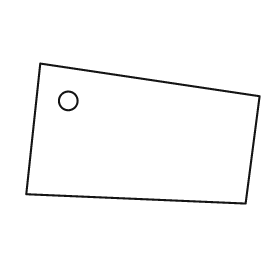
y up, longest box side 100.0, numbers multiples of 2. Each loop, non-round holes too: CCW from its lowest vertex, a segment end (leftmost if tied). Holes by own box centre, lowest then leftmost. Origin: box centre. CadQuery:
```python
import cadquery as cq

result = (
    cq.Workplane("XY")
    .moveTo(44.0, -30.0)
    .lineTo(50.0, 16.0)
    .lineTo(-44.0, 30.0)
    .lineTo(-50.0, -26.0)
    .close()
    .moveTo(-32.0, 14.0)
    .circle(4.0)
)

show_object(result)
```